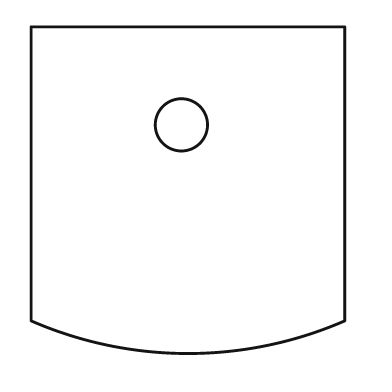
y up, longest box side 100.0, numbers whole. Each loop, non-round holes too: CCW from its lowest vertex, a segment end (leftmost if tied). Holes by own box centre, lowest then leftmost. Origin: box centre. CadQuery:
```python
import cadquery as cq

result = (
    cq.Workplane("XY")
    .moveTo(-48.0, -40.0)
    .threePointArc((0.0, -50.0), (48.0, -40.0))
    .lineTo(48.0, 50.0)
    .lineTo(-48.0, 50.0)
    .close()
    .moveTo(-2.0, 20.0)
    .circle(8.0)
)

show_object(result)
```